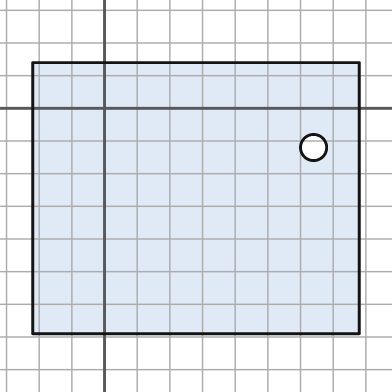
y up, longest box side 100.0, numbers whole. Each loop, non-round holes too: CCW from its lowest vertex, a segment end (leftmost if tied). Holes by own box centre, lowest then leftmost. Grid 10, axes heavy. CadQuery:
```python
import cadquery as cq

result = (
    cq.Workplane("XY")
    .moveTo(-22.0, -69.0)
    .lineTo(78.0, -69.0)
    .lineTo(78.0, 14.0)
    .lineTo(-22.0, 14.0)
    .close()
    .moveTo(64.0, -12.0)
    .circle(4.0)
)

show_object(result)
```